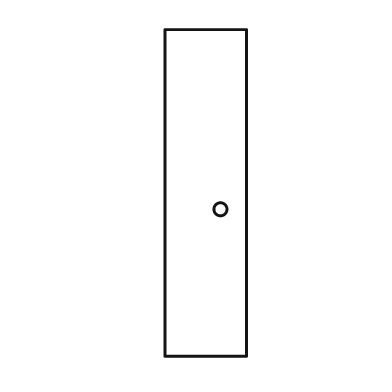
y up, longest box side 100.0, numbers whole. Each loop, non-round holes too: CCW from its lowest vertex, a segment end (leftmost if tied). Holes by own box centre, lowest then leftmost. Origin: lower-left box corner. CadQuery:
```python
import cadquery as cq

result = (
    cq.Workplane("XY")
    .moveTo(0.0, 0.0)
    .lineTo(25.0, 0.0)
    .lineTo(25.0, 100.0)
    .lineTo(0.0, 100.0)
    .close()
    .moveTo(17.0, 45.0)
    .circle(2.0)
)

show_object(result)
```